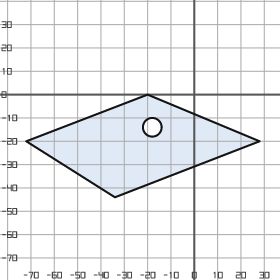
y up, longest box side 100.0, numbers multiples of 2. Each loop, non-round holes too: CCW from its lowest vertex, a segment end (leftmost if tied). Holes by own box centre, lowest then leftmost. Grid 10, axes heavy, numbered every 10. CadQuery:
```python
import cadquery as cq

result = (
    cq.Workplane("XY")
    .moveTo(-34.0, -44.0)
    .lineTo(28.0, -20.0)
    .lineTo(-20.0, 0.0)
    .lineTo(-72.0, -20.0)
    .close()
    .moveTo(-18.0, -14.0)
    .circle(4.0)
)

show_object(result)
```